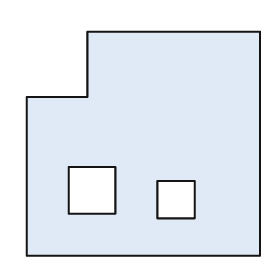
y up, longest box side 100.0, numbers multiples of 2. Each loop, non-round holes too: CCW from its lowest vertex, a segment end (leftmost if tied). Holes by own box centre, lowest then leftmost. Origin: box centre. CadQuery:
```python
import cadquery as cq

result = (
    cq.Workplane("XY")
    .moveTo(-50.0, -48.0)
    .lineTo(50.0, -48.0)
    .lineTo(50.0, 48.0)
    .lineTo(-24.0, 48.0)
    .lineTo(-24.0, 20.0)
    .lineTo(-50.0, 20.0)
    .close()
    .moveTo(6.0, -32.0)
    .lineTo(22.0, -32.0)
    .lineTo(22.0, -16.0)
    .lineTo(6.0, -16.0)
    .close()
    .moveTo(-32.0, -30.0)
    .lineTo(-12.0, -30.0)
    .lineTo(-12.0, -10.0)
    .lineTo(-32.0, -10.0)
    .close()
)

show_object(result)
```